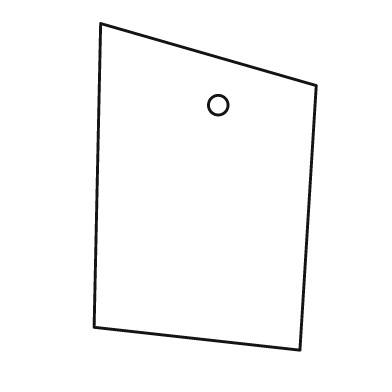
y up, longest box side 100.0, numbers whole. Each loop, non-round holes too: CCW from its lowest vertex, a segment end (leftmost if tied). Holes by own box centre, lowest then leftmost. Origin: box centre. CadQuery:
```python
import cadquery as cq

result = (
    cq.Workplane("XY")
    .moveTo(29.0, -50.0)
    .lineTo(34.0, 31.0)
    .lineTo(-32.0, 50.0)
    .lineTo(-34.0, -43.0)
    .close()
    .moveTo(4.0, 25.0)
    .circle(3.0)
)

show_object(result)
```